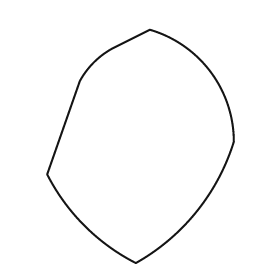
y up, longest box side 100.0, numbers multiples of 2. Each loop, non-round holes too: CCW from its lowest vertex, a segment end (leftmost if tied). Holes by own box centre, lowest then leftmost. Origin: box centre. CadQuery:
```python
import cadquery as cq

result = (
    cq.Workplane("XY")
    .moveTo(-2.0, -50.0)
    .threePointArc((24.0, -28.0), (40.0, 2.0))
    .threePointArc((30.0, 32.0), (4.0, 50.0))
    .lineTo(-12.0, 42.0)
    .threePointArc((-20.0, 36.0), (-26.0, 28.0))
    .lineTo(-40.0, -12.0)
    .threePointArc((-24.0, -34.0), (-2.0, -50.0))
    .close()
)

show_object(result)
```